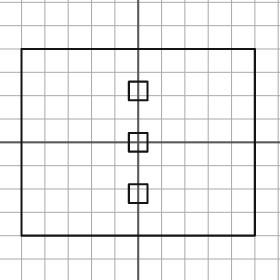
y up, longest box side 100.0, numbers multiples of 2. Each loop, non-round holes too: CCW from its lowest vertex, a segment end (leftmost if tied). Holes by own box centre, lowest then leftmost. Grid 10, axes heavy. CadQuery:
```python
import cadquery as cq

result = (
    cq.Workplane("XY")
    .moveTo(-50.0, -40.0)
    .lineTo(50.0, -40.0)
    .lineTo(50.0, 40.0)
    .lineTo(-50.0, 40.0)
    .close()
    .moveTo(-4.0, -26.0)
    .lineTo(4.0, -26.0)
    .lineTo(4.0, -18.0)
    .lineTo(-4.0, -18.0)
    .close()
    .moveTo(-4.0, -4.0)
    .lineTo(4.0, -4.0)
    .lineTo(4.0, 4.0)
    .lineTo(-4.0, 4.0)
    .close()
    .moveTo(-4.0, 18.0)
    .lineTo(4.0, 18.0)
    .lineTo(4.0, 26.0)
    .lineTo(-4.0, 26.0)
    .close()
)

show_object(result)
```